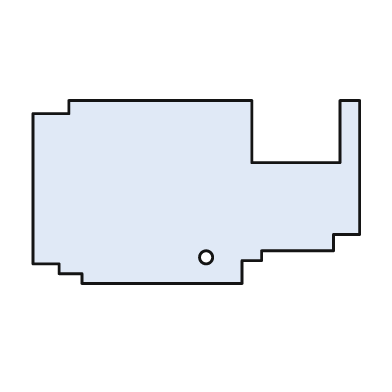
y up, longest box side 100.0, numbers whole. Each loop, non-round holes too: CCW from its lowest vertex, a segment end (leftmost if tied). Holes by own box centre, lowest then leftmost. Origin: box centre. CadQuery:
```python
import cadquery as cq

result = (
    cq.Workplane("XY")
    .moveTo(-35.0, -28.0)
    .lineTo(14.0, -28.0)
    .lineTo(14.0, -21.0)
    .lineTo(20.0, -21.0)
    .lineTo(20.0, -18.0)
    .lineTo(42.0, -18.0)
    .lineTo(42.0, -13.0)
    .lineTo(50.0, -13.0)
    .lineTo(50.0, 28.0)
    .lineTo(44.0, 28.0)
    .lineTo(44.0, 9.0)
    .lineTo(17.0, 9.0)
    .lineTo(17.0, 28.0)
    .lineTo(-39.0, 28.0)
    .lineTo(-39.0, 24.0)
    .lineTo(-50.0, 24.0)
    .lineTo(-50.0, -22.0)
    .lineTo(-42.0, -22.0)
    .lineTo(-42.0, -25.0)
    .lineTo(-35.0, -25.0)
    .close()
    .moveTo(3.0, -20.0)
    .circle(2.0)
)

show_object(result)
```